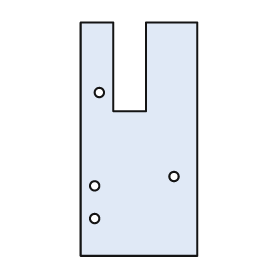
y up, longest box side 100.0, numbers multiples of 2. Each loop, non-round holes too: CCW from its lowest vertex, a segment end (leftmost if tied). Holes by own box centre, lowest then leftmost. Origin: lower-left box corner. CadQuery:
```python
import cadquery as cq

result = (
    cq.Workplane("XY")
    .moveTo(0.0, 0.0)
    .lineTo(50.0, 0.0)
    .lineTo(50.0, 100.0)
    .lineTo(28.0, 100.0)
    .lineTo(28.0, 62.0)
    .lineTo(14.0, 62.0)
    .lineTo(14.0, 100.0)
    .lineTo(0.0, 100.0)
    .close()
    .moveTo(6.0, 16.0)
    .circle(2.0)
    .moveTo(6.0, 30.0)
    .circle(2.0)
    .moveTo(40.0, 34.0)
    .circle(2.0)
    .moveTo(8.0, 70.0)
    .circle(2.0)
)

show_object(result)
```